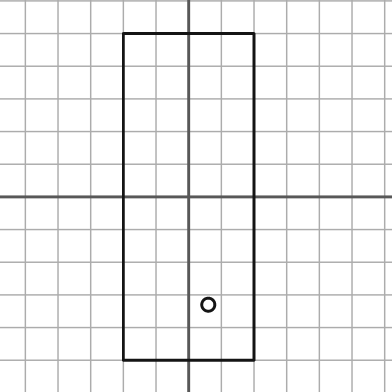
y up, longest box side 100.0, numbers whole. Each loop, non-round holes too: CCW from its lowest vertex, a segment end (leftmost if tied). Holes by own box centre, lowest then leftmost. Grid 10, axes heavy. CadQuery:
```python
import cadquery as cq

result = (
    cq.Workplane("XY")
    .moveTo(-20.0, -50.0)
    .lineTo(20.0, -50.0)
    .lineTo(20.0, 50.0)
    .lineTo(-20.0, 50.0)
    .close()
    .moveTo(6.0, -33.0)
    .circle(2.0)
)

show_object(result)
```